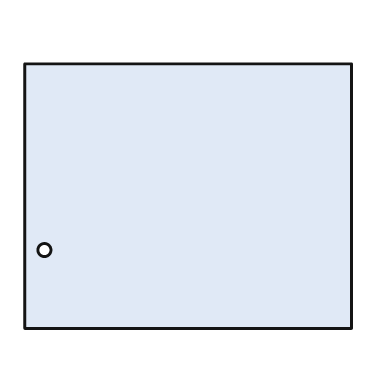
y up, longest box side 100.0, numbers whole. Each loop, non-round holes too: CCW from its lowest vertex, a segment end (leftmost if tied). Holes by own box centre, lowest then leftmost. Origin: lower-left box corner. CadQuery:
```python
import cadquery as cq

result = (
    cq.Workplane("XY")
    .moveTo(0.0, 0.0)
    .lineTo(100.0, 0.0)
    .lineTo(100.0, 81.0)
    .lineTo(0.0, 81.0)
    .close()
    .moveTo(6.0, 24.0)
    .circle(2.0)
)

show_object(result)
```